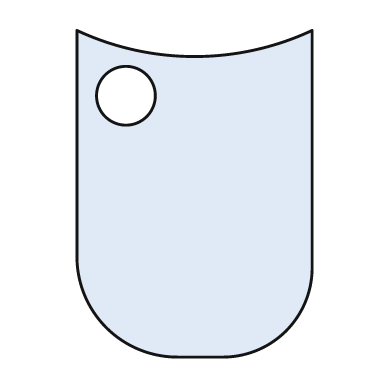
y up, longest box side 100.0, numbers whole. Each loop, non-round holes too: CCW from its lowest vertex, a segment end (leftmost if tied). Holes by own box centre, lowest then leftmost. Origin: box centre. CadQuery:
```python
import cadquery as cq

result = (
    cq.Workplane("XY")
    .moveTo(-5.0, -50.0)
    .lineTo(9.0, -50.0)
    .threePointArc((28.0, -42.0), (36.0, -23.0))
    .lineTo(36.0, 50.0)
    .threePointArc((0.0, 42.0), (-36.0, 50.0))
    .lineTo(-36.0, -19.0)
    .threePointArc((-27.0, -41.0), (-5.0, -50.0))
    .close()
    .moveTo(-21.0, 30.0)
    .circle(9.0)
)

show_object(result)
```